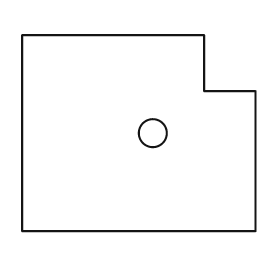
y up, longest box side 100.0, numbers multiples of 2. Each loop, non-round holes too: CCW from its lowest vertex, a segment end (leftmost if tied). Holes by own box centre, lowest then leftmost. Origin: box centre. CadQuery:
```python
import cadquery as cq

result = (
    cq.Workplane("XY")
    .moveTo(-50.0, -42.0)
    .lineTo(50.0, -42.0)
    .lineTo(50.0, 18.0)
    .lineTo(28.0, 18.0)
    .lineTo(28.0, 42.0)
    .lineTo(-50.0, 42.0)
    .close()
    .moveTo(6.0, 0.0)
    .circle(6.0)
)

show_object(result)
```